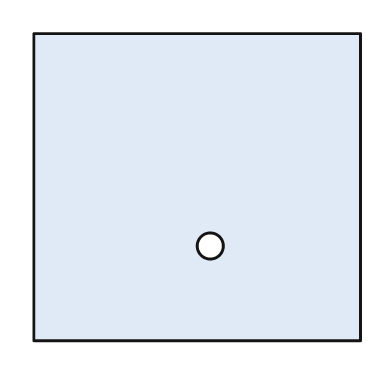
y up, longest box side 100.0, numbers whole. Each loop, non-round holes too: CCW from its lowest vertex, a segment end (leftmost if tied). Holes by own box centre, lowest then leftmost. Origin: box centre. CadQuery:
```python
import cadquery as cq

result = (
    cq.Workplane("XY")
    .moveTo(-50.0, -47.0)
    .lineTo(50.0, -47.0)
    .lineTo(50.0, 47.0)
    .lineTo(-50.0, 47.0)
    .close()
    .moveTo(4.0, -18.0)
    .circle(4.0)
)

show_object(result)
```